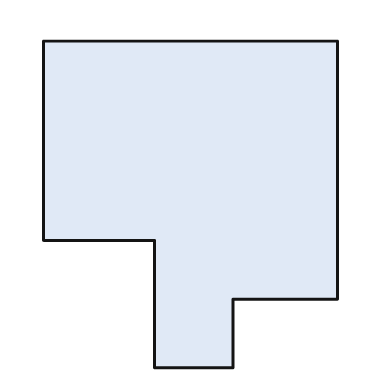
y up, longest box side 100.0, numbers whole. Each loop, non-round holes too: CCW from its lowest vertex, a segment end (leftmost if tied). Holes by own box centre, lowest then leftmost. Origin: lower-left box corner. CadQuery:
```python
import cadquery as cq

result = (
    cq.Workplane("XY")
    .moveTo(34.0, 0.0)
    .lineTo(58.0, 0.0)
    .lineTo(58.0, 21.0)
    .lineTo(90.0, 21.0)
    .lineTo(90.0, 100.0)
    .lineTo(0.0, 100.0)
    .lineTo(0.0, 39.0)
    .lineTo(34.0, 39.0)
    .close()
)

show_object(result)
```